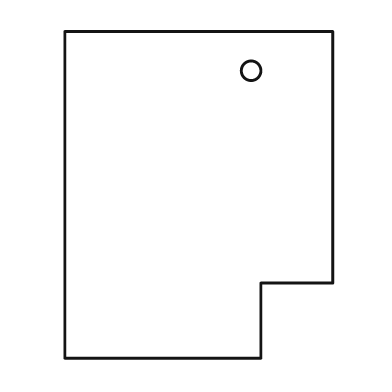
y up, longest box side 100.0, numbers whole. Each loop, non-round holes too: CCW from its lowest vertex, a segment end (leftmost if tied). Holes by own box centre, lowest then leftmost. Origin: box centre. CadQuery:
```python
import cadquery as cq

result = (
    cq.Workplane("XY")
    .moveTo(-41.0, -50.0)
    .lineTo(19.0, -50.0)
    .lineTo(19.0, -27.0)
    .lineTo(41.0, -27.0)
    .lineTo(41.0, 50.0)
    .lineTo(-41.0, 50.0)
    .close()
    .moveTo(16.0, 38.0)
    .circle(3.0)
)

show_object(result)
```